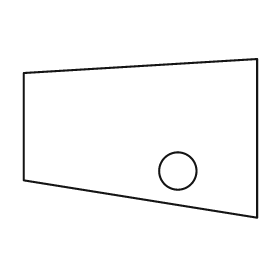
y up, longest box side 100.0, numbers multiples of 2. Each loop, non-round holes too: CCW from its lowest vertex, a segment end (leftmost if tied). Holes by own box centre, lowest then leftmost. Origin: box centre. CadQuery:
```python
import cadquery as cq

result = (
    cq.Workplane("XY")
    .moveTo(50.0, -34.0)
    .lineTo(50.0, 34.0)
    .lineTo(-50.0, 28.0)
    .lineTo(-50.0, -18.0)
    .close()
    .moveTo(16.0, -14.0)
    .circle(8.0)
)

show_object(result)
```